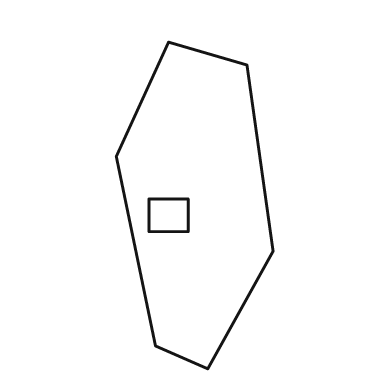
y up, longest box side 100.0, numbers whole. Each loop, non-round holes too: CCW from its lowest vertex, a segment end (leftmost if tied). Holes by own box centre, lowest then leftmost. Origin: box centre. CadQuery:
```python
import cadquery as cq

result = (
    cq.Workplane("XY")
    .moveTo(4.0, -50.0)
    .lineTo(24.0, -14.0)
    .lineTo(16.0, 43.0)
    .lineTo(-8.0, 50.0)
    .lineTo(-24.0, 15.0)
    .lineTo(-12.0, -43.0)
    .close()
    .moveTo(-14.0, -8.0)
    .lineTo(-2.0, -8.0)
    .lineTo(-2.0, 2.0)
    .lineTo(-14.0, 2.0)
    .close()
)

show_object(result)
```